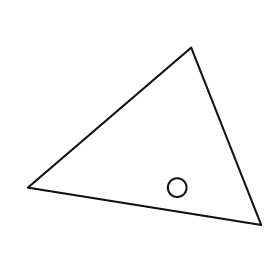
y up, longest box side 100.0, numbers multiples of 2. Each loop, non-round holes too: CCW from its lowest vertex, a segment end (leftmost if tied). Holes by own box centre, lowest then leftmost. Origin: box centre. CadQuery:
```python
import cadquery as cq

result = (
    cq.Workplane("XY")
    .moveTo(50.0, -38.0)
    .lineTo(20.0, 38.0)
    .lineTo(-50.0, -22.0)
    .close()
    .moveTo(14.0, -22.0)
    .circle(4.0)
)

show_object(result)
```